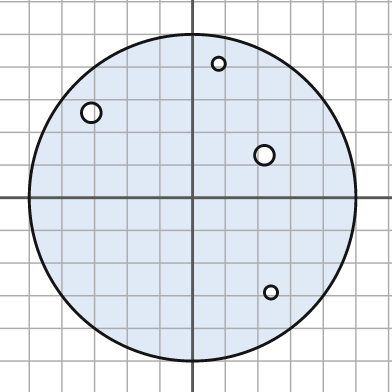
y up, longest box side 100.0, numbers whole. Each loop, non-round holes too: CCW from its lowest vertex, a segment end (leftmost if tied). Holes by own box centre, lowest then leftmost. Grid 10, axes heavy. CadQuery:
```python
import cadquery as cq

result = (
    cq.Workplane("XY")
    .moveTo(0.0, 0.0)
    .circle(50.0)
    .moveTo(24.0, -29.0)
    .circle(2.0)
    .moveTo(22.0, 13.0)
    .circle(3.0)
    .moveTo(-31.0, 26.0)
    .circle(3.0)
    .moveTo(8.0, 41.0)
    .circle(2.0)
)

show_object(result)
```